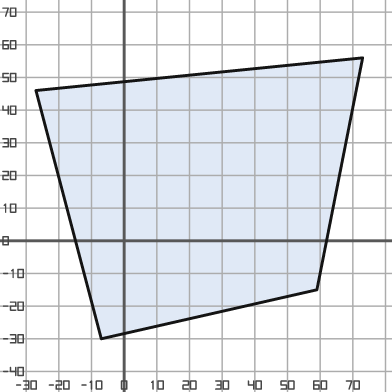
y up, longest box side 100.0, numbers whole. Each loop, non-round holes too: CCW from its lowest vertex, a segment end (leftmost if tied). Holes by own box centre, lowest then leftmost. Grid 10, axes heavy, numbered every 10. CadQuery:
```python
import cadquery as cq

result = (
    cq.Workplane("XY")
    .moveTo(-7.0, -30.0)
    .lineTo(59.0, -15.0)
    .lineTo(73.0, 56.0)
    .lineTo(-27.0, 46.0)
    .close()
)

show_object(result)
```